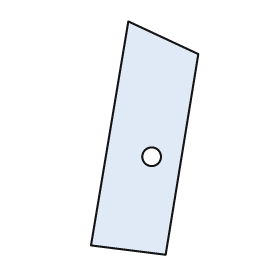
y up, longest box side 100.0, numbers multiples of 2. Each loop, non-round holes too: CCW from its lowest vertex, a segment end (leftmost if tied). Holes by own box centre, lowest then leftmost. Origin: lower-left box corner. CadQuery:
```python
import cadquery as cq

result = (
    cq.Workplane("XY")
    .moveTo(32.0, 0.0)
    .lineTo(46.0, 86.0)
    .lineTo(16.0, 100.0)
    .lineTo(0.0, 4.0)
    .close()
    .moveTo(26.0, 42.0)
    .circle(4.0)
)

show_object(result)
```